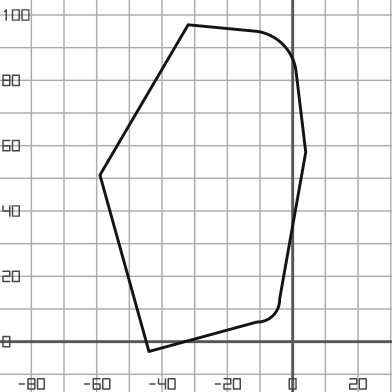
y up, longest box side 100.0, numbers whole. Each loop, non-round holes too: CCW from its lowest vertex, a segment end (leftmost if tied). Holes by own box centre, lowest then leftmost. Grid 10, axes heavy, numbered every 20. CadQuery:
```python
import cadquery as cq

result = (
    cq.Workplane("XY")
    .moveTo(-44.0, -3.0)
    .lineTo(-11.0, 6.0)
    .threePointArc((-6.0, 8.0), (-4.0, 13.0))
    .lineTo(4.0, 58.0)
    .lineTo(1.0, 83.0)
    .threePointArc((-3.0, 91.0), (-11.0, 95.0))
    .lineTo(-32.0, 97.0)
    .lineTo(-59.0, 51.0)
    .close()
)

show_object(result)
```